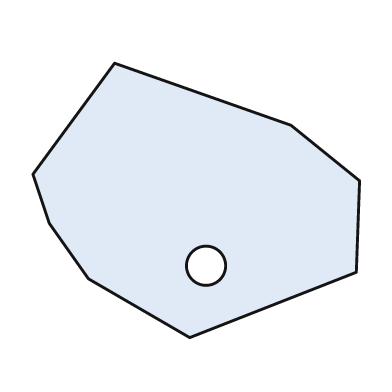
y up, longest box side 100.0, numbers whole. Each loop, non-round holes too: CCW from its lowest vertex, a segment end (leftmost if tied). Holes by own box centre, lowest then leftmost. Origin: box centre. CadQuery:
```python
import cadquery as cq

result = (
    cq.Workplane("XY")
    .moveTo(-2.0, -42.0)
    .lineTo(49.0, -22.0)
    .lineTo(50.0, 6.0)
    .lineTo(29.0, 23.0)
    .lineTo(-25.0, 42.0)
    .lineTo(-50.0, 8.0)
    .lineTo(-45.0, -7.0)
    .lineTo(-33.0, -24.0)
    .close()
    .moveTo(3.0, -20.0)
    .circle(6.0)
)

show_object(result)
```